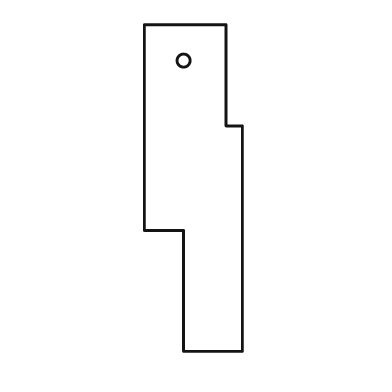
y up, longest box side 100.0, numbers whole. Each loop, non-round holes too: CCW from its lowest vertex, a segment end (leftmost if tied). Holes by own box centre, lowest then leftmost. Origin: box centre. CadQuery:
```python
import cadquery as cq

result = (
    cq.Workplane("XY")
    .moveTo(-3.0, -50.0)
    .lineTo(15.0, -50.0)
    .lineTo(15.0, 19.0)
    .lineTo(10.0, 19.0)
    .lineTo(10.0, 50.0)
    .lineTo(-15.0, 50.0)
    .lineTo(-15.0, -13.0)
    .lineTo(-3.0, -13.0)
    .close()
    .moveTo(-3.0, 39.0)
    .circle(2.0)
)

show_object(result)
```